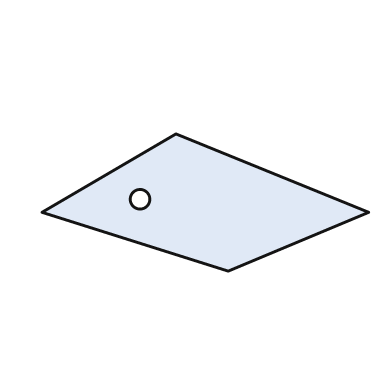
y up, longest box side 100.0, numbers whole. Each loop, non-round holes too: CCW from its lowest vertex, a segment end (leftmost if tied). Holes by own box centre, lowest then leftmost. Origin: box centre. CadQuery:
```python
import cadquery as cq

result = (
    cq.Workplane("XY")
    .moveTo(7.0, -21.0)
    .lineTo(50.0, -3.0)
    .lineTo(-9.0, 21.0)
    .lineTo(-50.0, -3.0)
    .close()
    .moveTo(-20.0, 1.0)
    .circle(3.0)
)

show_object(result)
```